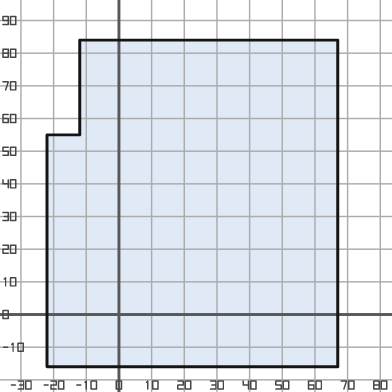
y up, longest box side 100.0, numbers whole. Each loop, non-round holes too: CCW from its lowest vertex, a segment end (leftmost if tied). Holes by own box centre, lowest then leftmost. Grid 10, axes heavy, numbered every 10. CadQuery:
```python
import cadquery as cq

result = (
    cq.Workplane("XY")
    .moveTo(-22.0, -16.0)
    .lineTo(67.0, -16.0)
    .lineTo(67.0, 84.0)
    .lineTo(-12.0, 84.0)
    .lineTo(-12.0, 55.0)
    .lineTo(-22.0, 55.0)
    .close()
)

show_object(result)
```